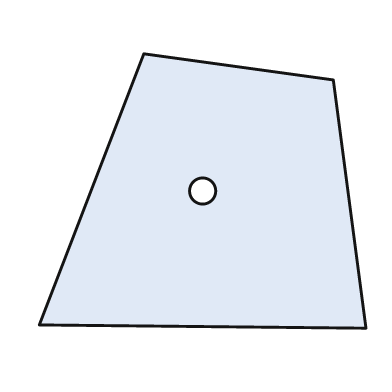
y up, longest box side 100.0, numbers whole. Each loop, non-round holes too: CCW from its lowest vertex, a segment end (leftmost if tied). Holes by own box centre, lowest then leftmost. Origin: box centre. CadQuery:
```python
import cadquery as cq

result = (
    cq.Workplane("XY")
    .moveTo(50.0, -42.0)
    .lineTo(40.0, 34.0)
    .lineTo(-18.0, 42.0)
    .lineTo(-50.0, -41.0)
    .close()
    .moveTo(0.0, 0.0)
    .circle(4.0)
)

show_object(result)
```